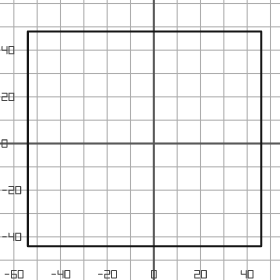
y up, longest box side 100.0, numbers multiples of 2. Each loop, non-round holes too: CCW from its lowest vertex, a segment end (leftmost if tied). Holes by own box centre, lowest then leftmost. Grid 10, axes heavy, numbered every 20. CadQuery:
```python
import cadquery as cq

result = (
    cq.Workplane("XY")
    .moveTo(-54.0, -44.0)
    .lineTo(46.0, -44.0)
    .lineTo(46.0, 48.0)
    .lineTo(-54.0, 48.0)
    .close()
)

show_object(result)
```